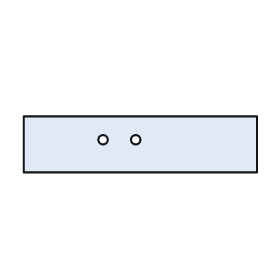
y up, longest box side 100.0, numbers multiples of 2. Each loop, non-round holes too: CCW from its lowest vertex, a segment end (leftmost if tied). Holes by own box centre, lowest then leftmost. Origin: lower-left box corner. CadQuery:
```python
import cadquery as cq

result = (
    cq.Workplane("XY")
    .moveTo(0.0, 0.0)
    .lineTo(100.0, 0.0)
    .lineTo(100.0, 24.0)
    .lineTo(0.0, 24.0)
    .close()
    .moveTo(34.0, 14.0)
    .circle(2.0)
    .moveTo(48.0, 14.0)
    .circle(2.0)
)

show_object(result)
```